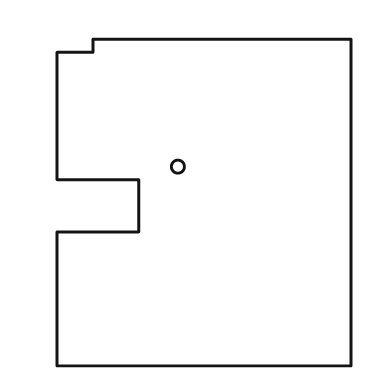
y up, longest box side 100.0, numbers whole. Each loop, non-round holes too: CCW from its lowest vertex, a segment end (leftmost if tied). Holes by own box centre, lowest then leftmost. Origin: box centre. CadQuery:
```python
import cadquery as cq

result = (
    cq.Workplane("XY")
    .moveTo(-45.0, -50.0)
    .lineTo(45.0, -50.0)
    .lineTo(45.0, 50.0)
    .lineTo(-34.0, 50.0)
    .lineTo(-34.0, 46.0)
    .lineTo(-45.0, 46.0)
    .lineTo(-45.0, 7.0)
    .lineTo(-20.0, 7.0)
    .lineTo(-20.0, -9.0)
    .lineTo(-45.0, -9.0)
    .close()
    .moveTo(-8.0, 11.0)
    .circle(2.0)
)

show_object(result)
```